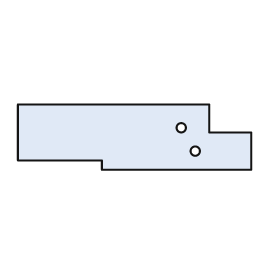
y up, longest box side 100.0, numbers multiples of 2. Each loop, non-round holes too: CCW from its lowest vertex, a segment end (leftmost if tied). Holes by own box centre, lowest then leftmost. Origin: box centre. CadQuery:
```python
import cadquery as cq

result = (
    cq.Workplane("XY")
    .moveTo(-14.0, -14.0)
    .lineTo(50.0, -14.0)
    .lineTo(50.0, 2.0)
    .lineTo(32.0, 2.0)
    .lineTo(32.0, 14.0)
    .lineTo(-50.0, 14.0)
    .lineTo(-50.0, -10.0)
    .lineTo(-14.0, -10.0)
    .close()
    .moveTo(26.0, -6.0)
    .circle(2.0)
    .moveTo(20.0, 4.0)
    .circle(2.0)
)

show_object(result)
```